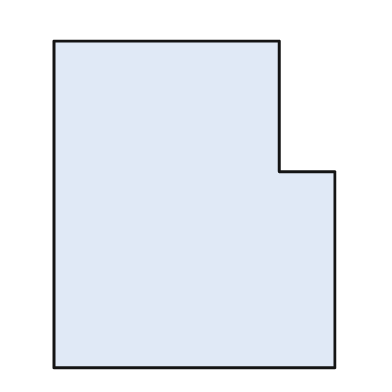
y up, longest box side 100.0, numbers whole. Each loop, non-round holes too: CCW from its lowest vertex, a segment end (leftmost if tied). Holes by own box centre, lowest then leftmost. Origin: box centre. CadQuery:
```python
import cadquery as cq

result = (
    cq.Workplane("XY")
    .moveTo(-43.0, -50.0)
    .lineTo(43.0, -50.0)
    .lineTo(43.0, 10.0)
    .lineTo(26.0, 10.0)
    .lineTo(26.0, 50.0)
    .lineTo(-43.0, 50.0)
    .close()
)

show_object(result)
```